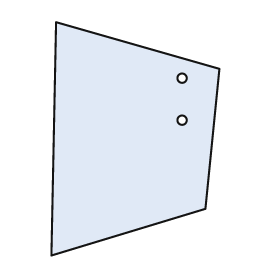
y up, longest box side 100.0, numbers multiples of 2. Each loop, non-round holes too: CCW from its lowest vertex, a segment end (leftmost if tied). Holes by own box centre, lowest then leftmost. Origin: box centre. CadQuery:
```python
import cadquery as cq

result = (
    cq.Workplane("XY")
    .moveTo(-36.0, -50.0)
    .lineTo(30.0, -30.0)
    .lineTo(36.0, 30.0)
    .lineTo(-34.0, 50.0)
    .close()
    .moveTo(20.0, 8.0)
    .circle(2.0)
    .moveTo(20.0, 26.0)
    .circle(2.0)
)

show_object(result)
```